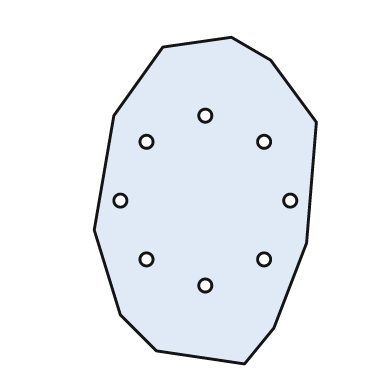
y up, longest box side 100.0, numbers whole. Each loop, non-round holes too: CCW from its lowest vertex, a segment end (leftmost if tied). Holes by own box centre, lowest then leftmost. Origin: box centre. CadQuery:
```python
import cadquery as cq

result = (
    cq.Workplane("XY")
    .moveTo(12.0, -50.0)
    .lineTo(21.0, -39.0)
    .lineTo(31.0, -13.0)
    .lineTo(34.0, 24.0)
    .lineTo(20.0, 43.0)
    .lineTo(8.0, 50.0)
    .lineTo(-13.0, 47.0)
    .lineTo(-28.0, 26.0)
    .lineTo(-34.0, -9.0)
    .lineTo(-26.0, -35.0)
    .lineTo(-15.0, -46.0)
    .close()
    .moveTo(0.0, -26.0)
    .circle(2.0)
    .moveTo(-18.0, -18.0)
    .circle(2.0)
    .moveTo(18.0, -18.0)
    .circle(2.0)
    .moveTo(-26.0, 0.0)
    .circle(2.0)
    .moveTo(26.0, 0.0)
    .circle(2.0)
    .moveTo(-18.0, 18.0)
    .circle(2.0)
    .moveTo(18.0, 18.0)
    .circle(2.0)
    .moveTo(0.0, 26.0)
    .circle(2.0)
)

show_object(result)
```